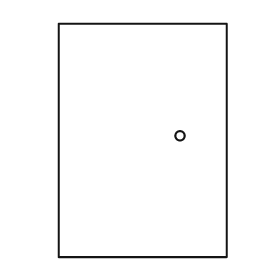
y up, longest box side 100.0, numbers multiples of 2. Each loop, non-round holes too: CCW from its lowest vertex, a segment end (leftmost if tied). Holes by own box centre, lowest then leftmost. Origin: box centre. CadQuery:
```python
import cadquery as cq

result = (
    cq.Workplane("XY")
    .moveTo(-36.0, -50.0)
    .lineTo(36.0, -50.0)
    .lineTo(36.0, 50.0)
    .lineTo(-36.0, 50.0)
    .close()
    .moveTo(16.0, 2.0)
    .circle(2.0)
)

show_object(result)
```